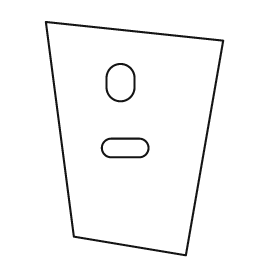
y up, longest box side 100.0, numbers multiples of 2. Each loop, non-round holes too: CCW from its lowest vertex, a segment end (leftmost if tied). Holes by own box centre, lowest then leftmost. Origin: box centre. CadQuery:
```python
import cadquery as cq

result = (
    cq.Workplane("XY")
    .moveTo(22.0, -50.0)
    .lineTo(38.0, 42.0)
    .lineTo(-38.0, 50.0)
    .lineTo(-26.0, -42.0)
    .close()
    .moveTo(-10.0, -8.0)
    .lineTo(2.0, -8.0)
    .threePointArc((6.0, -4.0), (2.0, 0.0))
    .lineTo(-10.0, 0.0)
    .threePointArc((-14.0, -4.0), (-10.0, -8.0))
    .close()
    .moveTo(-12.0, 22.0)
    .threePointArc((-6.0, 16.0), (0.0, 22.0))
    .lineTo(0.0, 26.0)
    .threePointArc((-6.0, 32.0), (-12.0, 26.0))
    .close()
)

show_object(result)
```